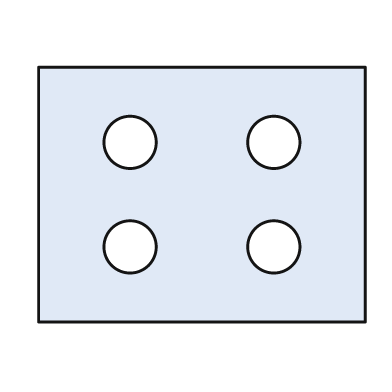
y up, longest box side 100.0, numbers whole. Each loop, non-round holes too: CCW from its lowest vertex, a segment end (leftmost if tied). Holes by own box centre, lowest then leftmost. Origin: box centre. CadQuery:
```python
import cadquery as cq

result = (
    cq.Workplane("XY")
    .moveTo(-50.0, -39.0)
    .lineTo(50.0, -39.0)
    .lineTo(50.0, 39.0)
    .lineTo(-50.0, 39.0)
    .close()
    .moveTo(-22.0, -16.0)
    .circle(8.0)
    .moveTo(22.0, -16.0)
    .circle(8.0)
    .moveTo(-22.0, 16.0)
    .circle(8.0)
    .moveTo(22.0, 16.0)
    .circle(8.0)
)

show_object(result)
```